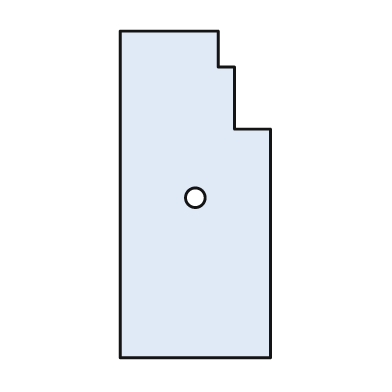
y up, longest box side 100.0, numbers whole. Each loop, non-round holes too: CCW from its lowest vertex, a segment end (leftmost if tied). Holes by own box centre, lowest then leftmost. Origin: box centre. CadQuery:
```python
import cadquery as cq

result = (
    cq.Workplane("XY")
    .moveTo(-23.0, -50.0)
    .lineTo(23.0, -50.0)
    .lineTo(23.0, 20.0)
    .lineTo(12.0, 20.0)
    .lineTo(12.0, 39.0)
    .lineTo(7.0, 39.0)
    .lineTo(7.0, 50.0)
    .lineTo(-23.0, 50.0)
    .close()
    .moveTo(0.0, -1.0)
    .circle(3.0)
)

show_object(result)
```